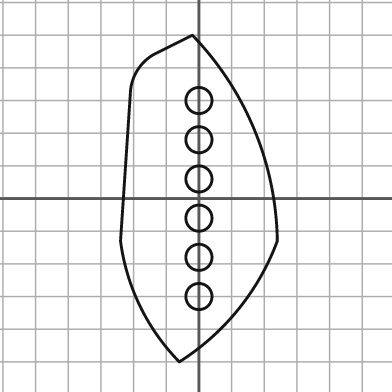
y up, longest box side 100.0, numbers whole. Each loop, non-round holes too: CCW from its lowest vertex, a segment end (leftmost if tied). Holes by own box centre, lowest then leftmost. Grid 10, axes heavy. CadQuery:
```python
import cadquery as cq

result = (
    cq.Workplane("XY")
    .moveTo(-6.0, -50.0)
    .threePointArc((12.0, -34.0), (24.0, -13.0))
    .threePointArc((17.0, 21.0), (-2.0, 50.0))
    .lineTo(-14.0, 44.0)
    .threePointArc((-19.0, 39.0), (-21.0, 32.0))
    .lineTo(-24.0, -13.0)
    .threePointArc((-18.0, -33.0), (-6.0, -50.0))
    .close()
    .moveTo(0.0, -30.0)
    .circle(4.0)
    .moveTo(0.0, -18.0)
    .circle(4.0)
    .moveTo(0.0, -6.0)
    .circle(4.0)
    .moveTo(0.0, 6.0)
    .circle(4.0)
    .moveTo(0.0, 18.0)
    .circle(4.0)
    .moveTo(0.0, 30.0)
    .circle(4.0)
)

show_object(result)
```